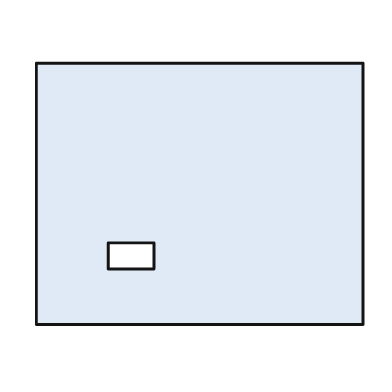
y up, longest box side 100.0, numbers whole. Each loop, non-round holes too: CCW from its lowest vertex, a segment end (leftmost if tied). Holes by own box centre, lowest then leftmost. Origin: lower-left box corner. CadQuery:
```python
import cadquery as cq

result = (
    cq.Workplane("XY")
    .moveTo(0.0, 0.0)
    .lineTo(100.0, 0.0)
    .lineTo(100.0, 80.0)
    .lineTo(0.0, 80.0)
    .close()
    .moveTo(22.0, 17.0)
    .lineTo(36.0, 17.0)
    .lineTo(36.0, 25.0)
    .lineTo(22.0, 25.0)
    .close()
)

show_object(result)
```